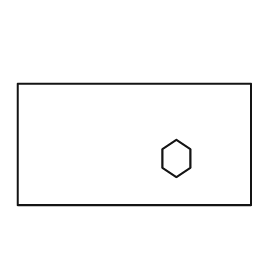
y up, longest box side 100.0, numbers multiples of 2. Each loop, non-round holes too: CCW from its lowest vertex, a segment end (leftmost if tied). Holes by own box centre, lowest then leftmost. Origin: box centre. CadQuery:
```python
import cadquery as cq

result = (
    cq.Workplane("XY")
    .moveTo(-50.0, -26.0)
    .lineTo(50.0, -26.0)
    .lineTo(50.0, 26.0)
    .lineTo(-50.0, 26.0)
    .close()
    .moveTo(18.0, -14.0)
    .lineTo(24.0, -10.0)
    .lineTo(24.0, -2.0)
    .lineTo(18.0, 2.0)
    .lineTo(12.0, -2.0)
    .lineTo(12.0, -10.0)
    .close()
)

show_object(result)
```